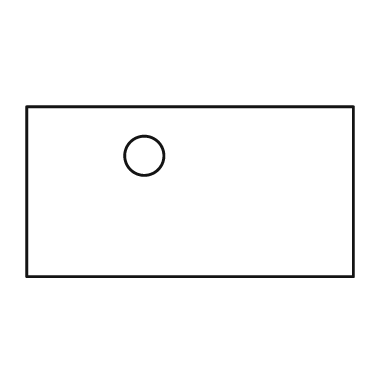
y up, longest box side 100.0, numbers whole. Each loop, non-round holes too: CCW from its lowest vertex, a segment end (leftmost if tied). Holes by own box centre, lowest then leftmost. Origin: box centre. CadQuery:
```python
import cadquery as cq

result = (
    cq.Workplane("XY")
    .moveTo(-50.0, -26.0)
    .lineTo(50.0, -26.0)
    .lineTo(50.0, 26.0)
    .lineTo(-50.0, 26.0)
    .close()
    .moveTo(-14.0, 11.0)
    .circle(6.0)
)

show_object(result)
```